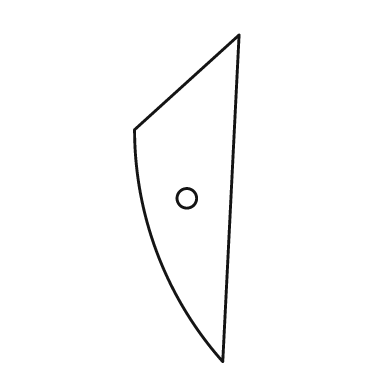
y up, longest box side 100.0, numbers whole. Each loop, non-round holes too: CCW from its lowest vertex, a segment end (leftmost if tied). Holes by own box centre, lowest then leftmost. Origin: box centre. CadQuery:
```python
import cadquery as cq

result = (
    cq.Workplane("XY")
    .moveTo(11.0, -50.0)
    .lineTo(16.0, 50.0)
    .lineTo(-16.0, 21.0)
    .threePointArc((-9.0, -17.0), (11.0, -50.0))
    .close()
    .moveTo(0.0, 0.0)
    .circle(3.0)
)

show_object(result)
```